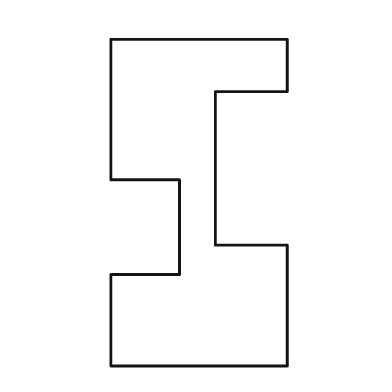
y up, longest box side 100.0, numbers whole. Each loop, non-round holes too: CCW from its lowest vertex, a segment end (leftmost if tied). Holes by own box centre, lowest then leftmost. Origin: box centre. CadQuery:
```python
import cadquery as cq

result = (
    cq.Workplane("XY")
    .moveTo(-27.0, -50.0)
    .lineTo(27.0, -50.0)
    .lineTo(27.0, -13.0)
    .lineTo(5.0, -13.0)
    .lineTo(5.0, 34.0)
    .lineTo(27.0, 34.0)
    .lineTo(27.0, 50.0)
    .lineTo(-27.0, 50.0)
    .lineTo(-27.0, 7.0)
    .lineTo(-6.0, 7.0)
    .lineTo(-6.0, -22.0)
    .lineTo(-27.0, -22.0)
    .close()
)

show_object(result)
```